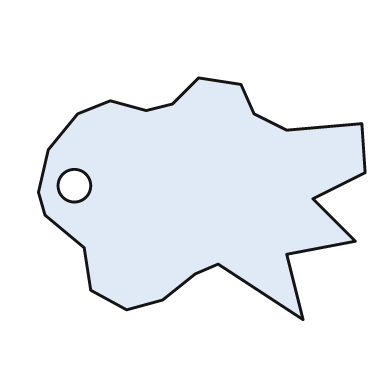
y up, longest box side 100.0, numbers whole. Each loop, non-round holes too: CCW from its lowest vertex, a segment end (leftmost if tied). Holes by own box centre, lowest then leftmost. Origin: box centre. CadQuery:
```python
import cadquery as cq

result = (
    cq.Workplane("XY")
    .moveTo(31.0, -37.0)
    .lineTo(26.0, -17.0)
    .lineTo(47.0, -13.0)
    .lineTo(34.0, 0.0)
    .lineTo(50.0, 8.0)
    .lineTo(49.0, 23.0)
    .lineTo(26.0, 21.0)
    .lineTo(16.0, 26.0)
    .lineTo(12.0, 35.0)
    .lineTo(-1.0, 37.0)
    .lineTo(-9.0, 29.0)
    .lineTo(-17.0, 27.0)
    .lineTo(-28.0, 30.0)
    .lineTo(-38.0, 26.0)
    .lineTo(-47.0, 15.0)
    .lineTo(-50.0, 2.0)
    .lineTo(-48.0, -5.0)
    .lineTo(-36.0, -15.0)
    .lineTo(-34.0, -28.0)
    .lineTo(-23.0, -34.0)
    .lineTo(-12.0, -31.0)
    .lineTo(-2.0, -23.0)
    .lineTo(5.0, -20.0)
    .close()
    .moveTo(-39.0, 4.0)
    .circle(5.0)
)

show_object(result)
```